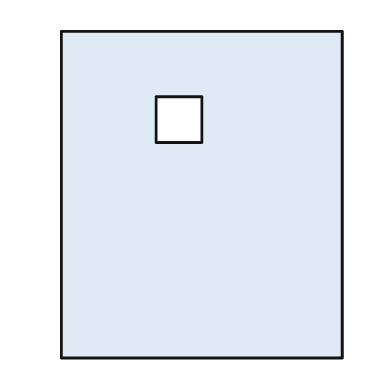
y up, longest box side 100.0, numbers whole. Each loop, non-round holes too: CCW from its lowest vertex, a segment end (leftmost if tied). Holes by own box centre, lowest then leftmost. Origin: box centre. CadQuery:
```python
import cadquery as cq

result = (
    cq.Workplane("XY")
    .moveTo(-43.0, -50.0)
    .lineTo(43.0, -50.0)
    .lineTo(43.0, 50.0)
    .lineTo(-43.0, 50.0)
    .close()
    .moveTo(-14.0, 16.0)
    .lineTo(0.0, 16.0)
    .lineTo(0.0, 30.0)
    .lineTo(-14.0, 30.0)
    .close()
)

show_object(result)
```